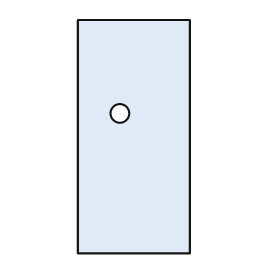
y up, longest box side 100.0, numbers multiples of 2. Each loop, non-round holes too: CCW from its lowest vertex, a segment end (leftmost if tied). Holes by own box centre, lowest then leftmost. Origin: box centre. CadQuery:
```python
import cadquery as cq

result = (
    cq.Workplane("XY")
    .moveTo(-24.0, -50.0)
    .lineTo(24.0, -50.0)
    .lineTo(24.0, 50.0)
    .lineTo(-24.0, 50.0)
    .close()
    .moveTo(-6.0, 10.0)
    .circle(4.0)
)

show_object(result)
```